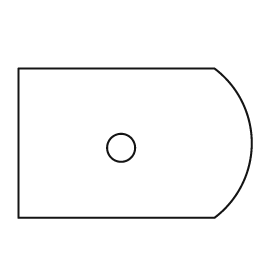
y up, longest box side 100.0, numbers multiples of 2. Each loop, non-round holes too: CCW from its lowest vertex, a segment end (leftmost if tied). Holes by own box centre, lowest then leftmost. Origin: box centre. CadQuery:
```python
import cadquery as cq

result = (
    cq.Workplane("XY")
    .moveTo(-50.0, -32.0)
    .lineTo(34.0, -32.0)
    .threePointArc((50.0, 0.0), (34.0, 32.0))
    .lineTo(-50.0, 32.0)
    .close()
    .moveTo(-6.0, -2.0)
    .circle(6.0)
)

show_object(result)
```